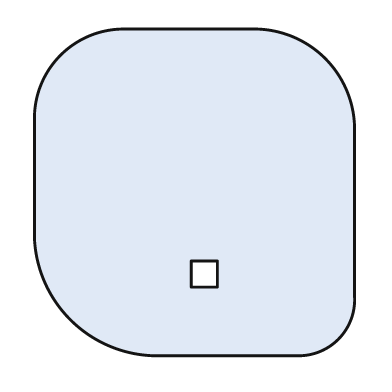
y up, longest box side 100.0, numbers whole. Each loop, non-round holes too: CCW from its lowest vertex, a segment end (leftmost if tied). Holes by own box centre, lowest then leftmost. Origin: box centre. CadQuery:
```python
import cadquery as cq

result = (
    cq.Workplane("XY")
    .moveTo(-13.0, -50.0)
    .lineTo(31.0, -50.0)
    .threePointArc((44.0, -45.0), (49.0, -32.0))
    .lineTo(49.0, 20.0)
    .threePointArc((40.0, 41.0), (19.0, 50.0))
    .lineTo(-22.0, 50.0)
    .threePointArc((-41.0, 42.0), (-49.0, 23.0))
    .lineTo(-49.0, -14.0)
    .threePointArc((-38.0, -39.0), (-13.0, -50.0))
    .close()
    .moveTo(-1.0, -29.0)
    .lineTo(7.0, -29.0)
    .lineTo(7.0, -21.0)
    .lineTo(-1.0, -21.0)
    .close()
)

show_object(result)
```